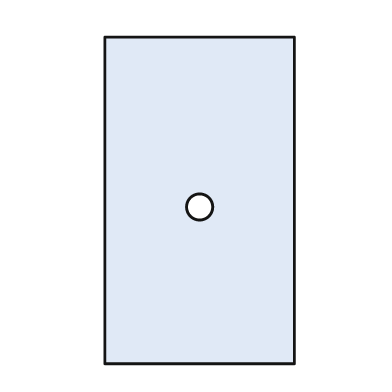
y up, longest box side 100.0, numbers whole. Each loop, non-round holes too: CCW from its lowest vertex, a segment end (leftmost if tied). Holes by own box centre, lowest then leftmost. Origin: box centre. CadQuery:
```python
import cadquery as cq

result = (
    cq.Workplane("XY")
    .moveTo(-29.0, -50.0)
    .lineTo(29.0, -50.0)
    .lineTo(29.0, 50.0)
    .lineTo(-29.0, 50.0)
    .close()
    .moveTo(0.0, -2.0)
    .circle(4.0)
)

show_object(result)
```